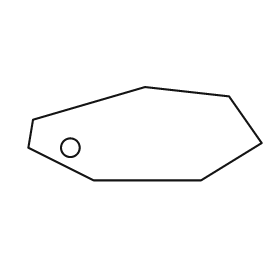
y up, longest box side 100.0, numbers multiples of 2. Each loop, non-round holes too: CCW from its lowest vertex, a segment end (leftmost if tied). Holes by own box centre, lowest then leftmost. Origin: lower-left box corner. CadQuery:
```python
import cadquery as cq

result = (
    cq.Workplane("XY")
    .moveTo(28.0, 0.0)
    .lineTo(74.0, 0.0)
    .lineTo(100.0, 16.0)
    .lineTo(86.0, 36.0)
    .lineTo(50.0, 40.0)
    .lineTo(2.0, 26.0)
    .lineTo(0.0, 14.0)
    .close()
    .moveTo(18.0, 14.0)
    .circle(4.0)
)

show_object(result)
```